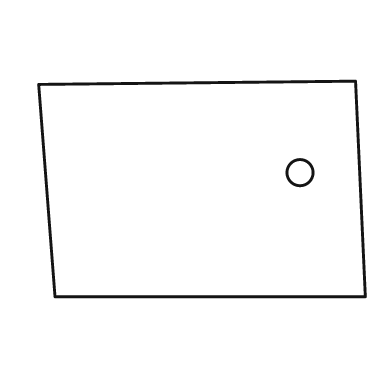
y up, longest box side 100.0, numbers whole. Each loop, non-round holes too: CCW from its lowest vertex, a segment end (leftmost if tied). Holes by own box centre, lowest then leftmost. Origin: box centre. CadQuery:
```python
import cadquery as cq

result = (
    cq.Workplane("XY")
    .moveTo(-45.0, -33.0)
    .lineTo(50.0, -33.0)
    .lineTo(47.0, 33.0)
    .lineTo(-50.0, 32.0)
    .close()
    .moveTo(30.0, 5.0)
    .circle(4.0)
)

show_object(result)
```